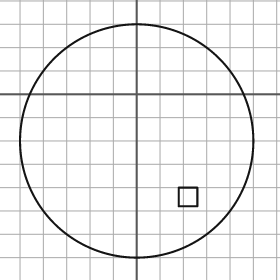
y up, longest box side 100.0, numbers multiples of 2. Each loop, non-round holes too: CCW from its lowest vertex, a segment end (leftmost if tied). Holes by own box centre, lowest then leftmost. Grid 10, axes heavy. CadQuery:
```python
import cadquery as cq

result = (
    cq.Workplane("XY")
    .moveTo(0.0, -20.0)
    .circle(50.0)
    .moveTo(18.0, -48.0)
    .lineTo(26.0, -48.0)
    .lineTo(26.0, -40.0)
    .lineTo(18.0, -40.0)
    .close()
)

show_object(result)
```